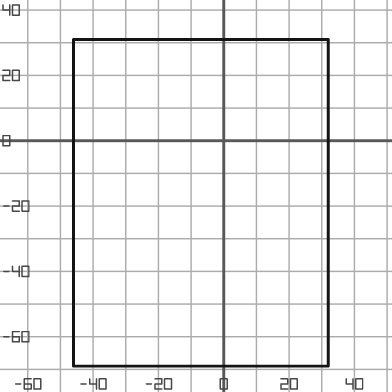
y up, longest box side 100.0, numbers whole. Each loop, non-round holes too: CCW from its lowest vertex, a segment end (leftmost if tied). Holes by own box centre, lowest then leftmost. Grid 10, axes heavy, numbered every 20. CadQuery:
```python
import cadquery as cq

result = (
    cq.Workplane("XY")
    .moveTo(-46.0, -69.0)
    .lineTo(32.0, -69.0)
    .lineTo(32.0, 31.0)
    .lineTo(-46.0, 31.0)
    .close()
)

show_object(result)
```